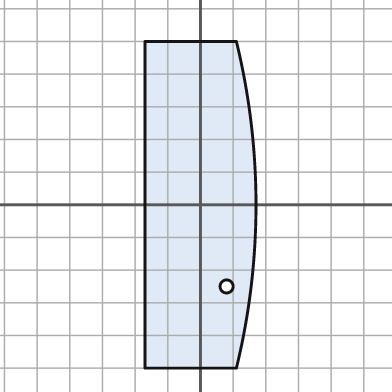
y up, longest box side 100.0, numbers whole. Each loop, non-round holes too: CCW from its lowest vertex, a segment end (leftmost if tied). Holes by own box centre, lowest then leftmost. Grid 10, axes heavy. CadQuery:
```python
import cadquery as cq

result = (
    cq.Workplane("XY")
    .moveTo(-17.0, -50.0)
    .lineTo(11.0, -50.0)
    .threePointArc((17.0, 0.0), (11.0, 50.0))
    .lineTo(-17.0, 50.0)
    .close()
    .moveTo(8.0, -25.0)
    .circle(2.0)
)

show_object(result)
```